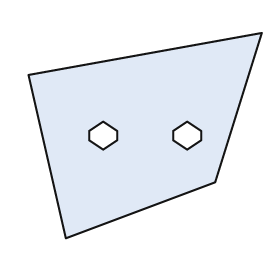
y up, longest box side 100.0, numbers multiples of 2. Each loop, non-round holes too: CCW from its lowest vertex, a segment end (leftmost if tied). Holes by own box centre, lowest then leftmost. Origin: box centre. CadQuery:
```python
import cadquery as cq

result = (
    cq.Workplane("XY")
    .moveTo(-34.0, -44.0)
    .lineTo(30.0, -20.0)
    .lineTo(50.0, 44.0)
    .lineTo(-50.0, 26.0)
    .close()
    .moveTo(-18.0, -6.0)
    .lineTo(-12.0, -2.0)
    .lineTo(-12.0, 2.0)
    .lineTo(-18.0, 6.0)
    .lineTo(-24.0, 2.0)
    .lineTo(-24.0, -2.0)
    .close()
    .moveTo(18.0, -6.0)
    .lineTo(24.0, -2.0)
    .lineTo(24.0, 2.0)
    .lineTo(18.0, 6.0)
    .lineTo(12.0, 2.0)
    .lineTo(12.0, -2.0)
    .close()
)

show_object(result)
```